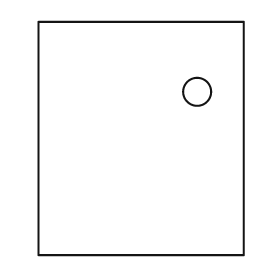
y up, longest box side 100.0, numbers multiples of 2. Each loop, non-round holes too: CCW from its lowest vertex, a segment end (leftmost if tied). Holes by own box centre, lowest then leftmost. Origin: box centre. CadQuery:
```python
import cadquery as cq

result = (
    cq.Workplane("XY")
    .moveTo(-44.0, -50.0)
    .lineTo(44.0, -50.0)
    .lineTo(44.0, 50.0)
    .lineTo(-44.0, 50.0)
    .close()
    .moveTo(24.0, 20.0)
    .circle(6.0)
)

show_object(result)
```